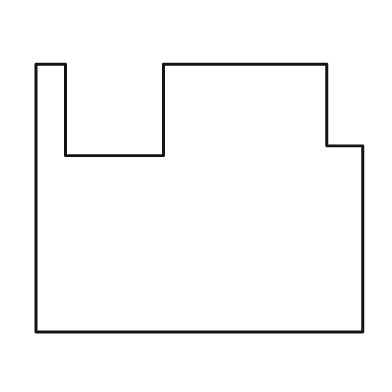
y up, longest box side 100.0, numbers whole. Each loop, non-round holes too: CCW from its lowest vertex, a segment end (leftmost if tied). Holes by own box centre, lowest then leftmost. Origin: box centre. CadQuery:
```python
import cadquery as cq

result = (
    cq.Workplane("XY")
    .moveTo(-50.0, -41.0)
    .lineTo(50.0, -41.0)
    .lineTo(50.0, 16.0)
    .lineTo(39.0, 16.0)
    .lineTo(39.0, 41.0)
    .lineTo(-11.0, 41.0)
    .lineTo(-11.0, 13.0)
    .lineTo(-41.0, 13.0)
    .lineTo(-41.0, 41.0)
    .lineTo(-50.0, 41.0)
    .close()
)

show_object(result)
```